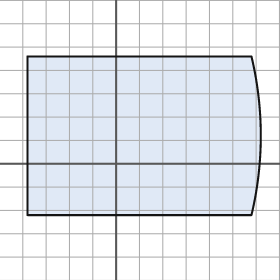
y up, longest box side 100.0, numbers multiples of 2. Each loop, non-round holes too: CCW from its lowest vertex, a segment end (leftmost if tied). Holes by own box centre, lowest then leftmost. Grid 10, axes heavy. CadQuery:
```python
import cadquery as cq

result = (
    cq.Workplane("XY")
    .moveTo(-38.0, -22.0)
    .lineTo(58.0, -22.0)
    .threePointArc((62.0, 12.0), (58.0, 46.0))
    .lineTo(-38.0, 46.0)
    .close()
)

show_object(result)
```